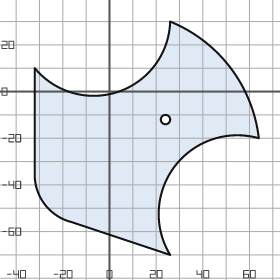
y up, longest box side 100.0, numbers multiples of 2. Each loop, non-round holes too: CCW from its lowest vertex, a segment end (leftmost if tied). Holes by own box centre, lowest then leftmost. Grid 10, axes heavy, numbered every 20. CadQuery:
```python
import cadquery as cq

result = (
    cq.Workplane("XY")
    .moveTo(26.0, -70.0)
    .threePointArc((28.0, -32.0), (64.0, -20.0))
    .threePointArc((52.0, 10.0), (26.0, 30.0))
    .threePointArc((4.0, 0.0), (-32.0, 10.0))
    .lineTo(-32.0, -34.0)
    .threePointArc((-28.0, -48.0), (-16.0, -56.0))
    .close()
    .moveTo(24.0, -12.0)
    .circle(2.0)
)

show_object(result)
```